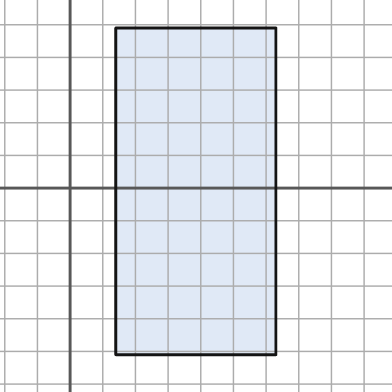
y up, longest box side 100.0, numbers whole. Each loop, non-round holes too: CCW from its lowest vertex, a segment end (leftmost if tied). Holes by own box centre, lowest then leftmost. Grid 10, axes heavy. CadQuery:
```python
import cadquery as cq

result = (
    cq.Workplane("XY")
    .moveTo(14.0, -51.0)
    .lineTo(63.0, -51.0)
    .lineTo(63.0, 49.0)
    .lineTo(14.0, 49.0)
    .close()
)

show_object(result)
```